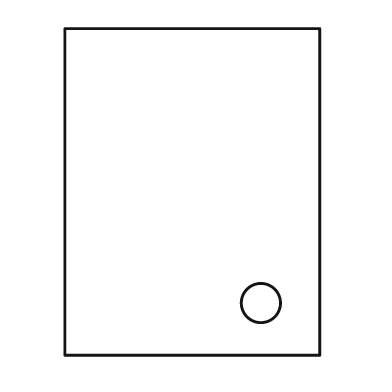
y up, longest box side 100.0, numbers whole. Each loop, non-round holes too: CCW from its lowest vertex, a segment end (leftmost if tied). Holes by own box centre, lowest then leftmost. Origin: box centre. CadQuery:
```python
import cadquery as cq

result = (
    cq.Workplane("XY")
    .moveTo(-39.0, -50.0)
    .lineTo(39.0, -50.0)
    .lineTo(39.0, 50.0)
    .lineTo(-39.0, 50.0)
    .close()
    .moveTo(21.0, -34.0)
    .circle(6.0)
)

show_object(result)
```